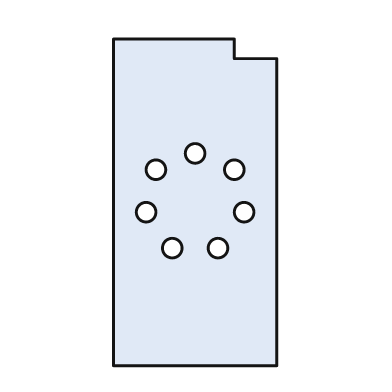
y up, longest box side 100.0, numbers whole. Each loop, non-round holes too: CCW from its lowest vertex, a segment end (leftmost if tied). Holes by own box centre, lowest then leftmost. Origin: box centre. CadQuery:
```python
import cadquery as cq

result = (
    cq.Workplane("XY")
    .moveTo(-25.0, -50.0)
    .lineTo(25.0, -50.0)
    .lineTo(25.0, 44.0)
    .lineTo(12.0, 44.0)
    .lineTo(12.0, 50.0)
    .lineTo(-25.0, 50.0)
    .close()
    .moveTo(-7.0, -14.0)
    .circle(3.0)
    .moveTo(7.0, -14.0)
    .circle(3.0)
    .moveTo(-15.0, -3.0)
    .circle(3.0)
    .moveTo(15.0, -3.0)
    .circle(3.0)
    .moveTo(-12.0, 10.0)
    .circle(3.0)
    .moveTo(12.0, 10.0)
    .circle(3.0)
    .moveTo(0.0, 15.0)
    .circle(3.0)
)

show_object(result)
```